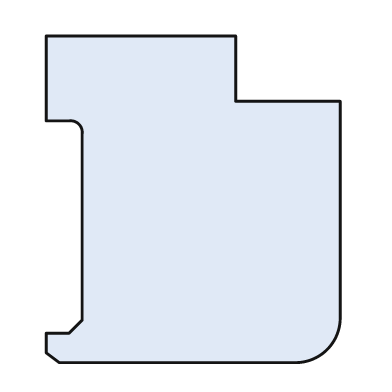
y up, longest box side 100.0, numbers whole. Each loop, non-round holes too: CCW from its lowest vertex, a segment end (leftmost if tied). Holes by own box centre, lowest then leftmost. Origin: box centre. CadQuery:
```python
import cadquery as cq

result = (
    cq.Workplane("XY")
    .moveTo(-41.0, -50.0)
    .lineTo(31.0, -50.0)
    .threePointArc((41.0, -46.0), (45.0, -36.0))
    .lineTo(45.0, 30.0)
    .lineTo(13.0, 30.0)
    .lineTo(13.0, 50.0)
    .lineTo(-45.0, 50.0)
    .lineTo(-45.0, 24.0)
    .lineTo(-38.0, 24.0)
    .threePointArc((-35.0, 23.0), (-34.0, 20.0))
    .lineTo(-34.0, -37.0)
    .lineTo(-38.0, -41.0)
    .lineTo(-45.0, -41.0)
    .lineTo(-45.0, -47.0)
    .close()
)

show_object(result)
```